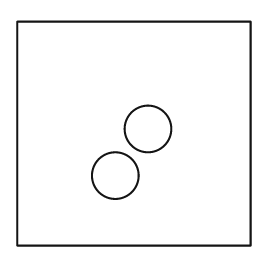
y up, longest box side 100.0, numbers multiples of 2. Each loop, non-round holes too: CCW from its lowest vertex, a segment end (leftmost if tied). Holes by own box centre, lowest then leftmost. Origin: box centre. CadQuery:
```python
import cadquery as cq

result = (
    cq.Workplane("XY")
    .moveTo(-50.0, -48.0)
    .lineTo(50.0, -48.0)
    .lineTo(50.0, 48.0)
    .lineTo(-50.0, 48.0)
    .close()
    .moveTo(-8.0, -18.0)
    .circle(10.0)
    .moveTo(6.0, 2.0)
    .circle(10.0)
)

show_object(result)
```